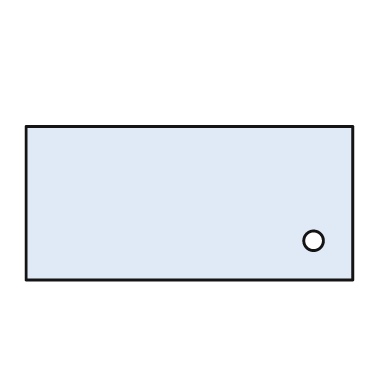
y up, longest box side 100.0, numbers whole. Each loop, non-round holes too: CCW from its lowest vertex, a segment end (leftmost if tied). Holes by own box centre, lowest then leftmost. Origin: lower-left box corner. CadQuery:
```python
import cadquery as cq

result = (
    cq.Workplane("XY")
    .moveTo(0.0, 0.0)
    .lineTo(100.0, 0.0)
    .lineTo(100.0, 47.0)
    .lineTo(0.0, 47.0)
    .close()
    .moveTo(88.0, 12.0)
    .circle(3.0)
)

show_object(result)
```